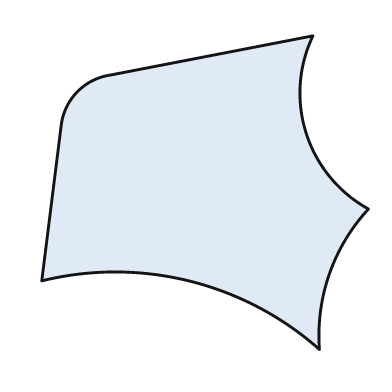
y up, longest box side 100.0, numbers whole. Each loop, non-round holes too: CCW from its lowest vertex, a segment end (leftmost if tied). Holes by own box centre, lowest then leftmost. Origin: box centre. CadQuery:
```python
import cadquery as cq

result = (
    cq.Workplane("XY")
    .moveTo(35.0, -48.0)
    .threePointArc((38.0, -25.0), (50.0, -5.0))
    .threePointArc((31.0, 18.0), (33.0, 48.0))
    .lineTo(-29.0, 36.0)
    .threePointArc((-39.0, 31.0), (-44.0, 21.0))
    .lineTo(-50.0, -27.0)
    .threePointArc((-5.0, -27.0), (35.0, -48.0))
    .close()
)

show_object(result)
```